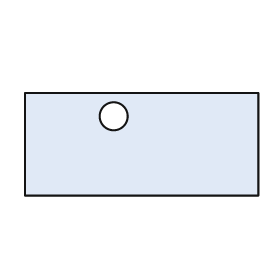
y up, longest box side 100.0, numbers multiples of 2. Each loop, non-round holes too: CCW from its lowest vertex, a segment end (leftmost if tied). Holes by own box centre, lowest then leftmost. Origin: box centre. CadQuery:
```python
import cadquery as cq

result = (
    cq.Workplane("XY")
    .moveTo(-50.0, -22.0)
    .lineTo(50.0, -22.0)
    .lineTo(50.0, 22.0)
    .lineTo(-50.0, 22.0)
    .close()
    .moveTo(-12.0, 12.0)
    .circle(6.0)
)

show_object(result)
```